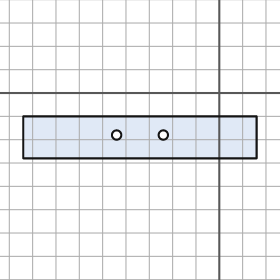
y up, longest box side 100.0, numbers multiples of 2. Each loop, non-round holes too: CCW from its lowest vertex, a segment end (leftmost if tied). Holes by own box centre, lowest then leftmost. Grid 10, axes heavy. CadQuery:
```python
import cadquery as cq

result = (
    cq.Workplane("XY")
    .moveTo(-84.0, -28.0)
    .lineTo(16.0, -28.0)
    .lineTo(16.0, -10.0)
    .lineTo(-84.0, -10.0)
    .close()
    .moveTo(-44.0, -18.0)
    .circle(2.0)
    .moveTo(-24.0, -18.0)
    .circle(2.0)
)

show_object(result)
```